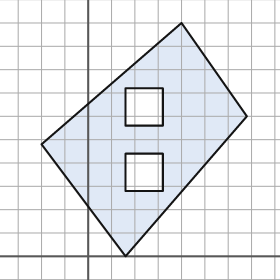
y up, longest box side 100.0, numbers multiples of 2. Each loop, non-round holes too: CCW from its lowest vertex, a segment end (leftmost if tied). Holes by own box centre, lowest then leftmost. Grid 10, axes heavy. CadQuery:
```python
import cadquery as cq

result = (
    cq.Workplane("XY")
    .moveTo(16.0, 0.0)
    .lineTo(68.0, 60.0)
    .lineTo(40.0, 100.0)
    .lineTo(-20.0, 48.0)
    .close()
    .moveTo(16.0, 28.0)
    .lineTo(32.0, 28.0)
    .lineTo(32.0, 44.0)
    .lineTo(16.0, 44.0)
    .close()
    .moveTo(16.0, 56.0)
    .lineTo(32.0, 56.0)
    .lineTo(32.0, 72.0)
    .lineTo(16.0, 72.0)
    .close()
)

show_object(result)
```